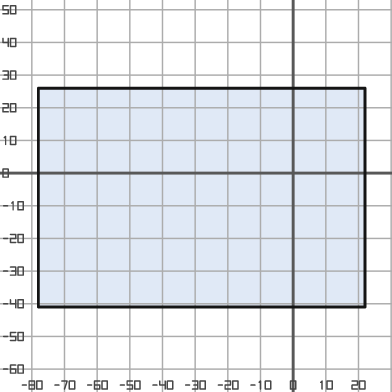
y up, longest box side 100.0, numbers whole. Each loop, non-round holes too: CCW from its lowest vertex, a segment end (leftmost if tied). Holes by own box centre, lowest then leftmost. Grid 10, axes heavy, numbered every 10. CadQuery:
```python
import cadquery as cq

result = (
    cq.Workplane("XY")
    .moveTo(-78.0, -41.0)
    .lineTo(22.0, -41.0)
    .lineTo(22.0, 26.0)
    .lineTo(-78.0, 26.0)
    .close()
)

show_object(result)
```